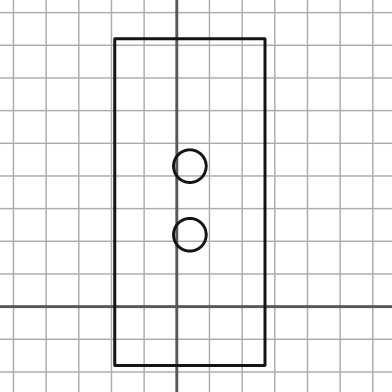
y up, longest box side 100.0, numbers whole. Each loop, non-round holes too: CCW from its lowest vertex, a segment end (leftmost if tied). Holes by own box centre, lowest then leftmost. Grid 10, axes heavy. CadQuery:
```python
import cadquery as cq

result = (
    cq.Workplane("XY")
    .moveTo(-19.0, -18.0)
    .lineTo(27.0, -18.0)
    .lineTo(27.0, 82.0)
    .lineTo(-19.0, 82.0)
    .close()
    .moveTo(4.0, 22.0)
    .circle(5.0)
    .moveTo(4.0, 43.0)
    .circle(5.0)
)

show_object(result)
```